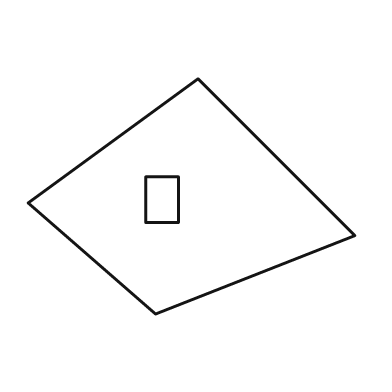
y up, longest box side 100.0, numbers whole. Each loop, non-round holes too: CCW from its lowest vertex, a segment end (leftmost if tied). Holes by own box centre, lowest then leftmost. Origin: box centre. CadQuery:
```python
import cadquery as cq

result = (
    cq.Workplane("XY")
    .moveTo(-11.0, -36.0)
    .lineTo(50.0, -12.0)
    .lineTo(2.0, 36.0)
    .lineTo(-50.0, -2.0)
    .close()
    .moveTo(-14.0, -8.0)
    .lineTo(-4.0, -8.0)
    .lineTo(-4.0, 6.0)
    .lineTo(-14.0, 6.0)
    .close()
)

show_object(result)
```